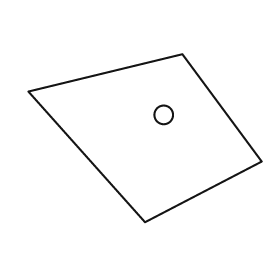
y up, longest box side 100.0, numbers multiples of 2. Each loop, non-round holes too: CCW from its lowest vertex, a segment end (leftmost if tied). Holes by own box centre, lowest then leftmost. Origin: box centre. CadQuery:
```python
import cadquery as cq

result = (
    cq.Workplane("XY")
    .moveTo(0.0, -36.0)
    .lineTo(50.0, -10.0)
    .lineTo(16.0, 36.0)
    .lineTo(-50.0, 20.0)
    .close()
    .moveTo(8.0, 10.0)
    .circle(4.0)
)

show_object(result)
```